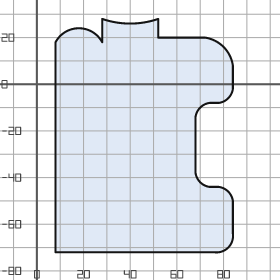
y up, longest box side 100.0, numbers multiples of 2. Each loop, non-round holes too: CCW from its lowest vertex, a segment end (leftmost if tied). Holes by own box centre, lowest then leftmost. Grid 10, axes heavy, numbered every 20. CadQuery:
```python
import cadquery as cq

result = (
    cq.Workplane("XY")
    .moveTo(8.0, -72.0)
    .lineTo(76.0, -72.0)
    .threePointArc((82.0, -70.0), (84.0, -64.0))
    .lineTo(84.0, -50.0)
    .threePointArc((82.0, -46.0), (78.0, -44.0))
    .lineTo(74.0, -44.0)
    .threePointArc((70.0, -42.0), (68.0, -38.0))
    .lineTo(68.0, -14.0)
    .threePointArc((70.0, -10.0), (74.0, -8.0))
    .lineTo(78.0, -8.0)
    .threePointArc((82.0, -6.0), (84.0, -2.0))
    .lineTo(84.0, 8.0)
    .threePointArc((80.0, 16.0), (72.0, 20.0))
    .lineTo(52.0, 20.0)
    .lineTo(52.0, 28.0)
    .threePointArc((40.0, 26.0), (28.0, 28.0))
    .lineTo(28.0, 18.0)
    .threePointArc((18.0, 24.0), (8.0, 18.0))
    .close()
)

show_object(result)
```